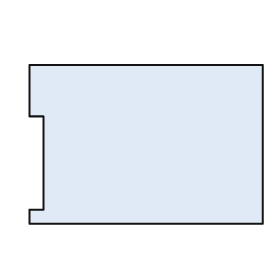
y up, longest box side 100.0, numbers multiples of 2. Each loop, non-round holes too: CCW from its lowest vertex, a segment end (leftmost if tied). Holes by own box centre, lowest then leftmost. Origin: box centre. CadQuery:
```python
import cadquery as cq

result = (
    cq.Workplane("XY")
    .moveTo(-50.0, -34.0)
    .lineTo(50.0, -34.0)
    .lineTo(50.0, 34.0)
    .lineTo(-50.0, 34.0)
    .lineTo(-50.0, 12.0)
    .lineTo(-44.0, 12.0)
    .lineTo(-44.0, -28.0)
    .lineTo(-50.0, -28.0)
    .close()
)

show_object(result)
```